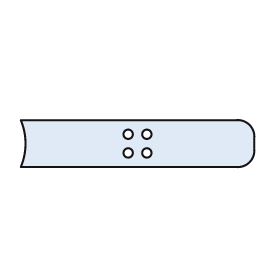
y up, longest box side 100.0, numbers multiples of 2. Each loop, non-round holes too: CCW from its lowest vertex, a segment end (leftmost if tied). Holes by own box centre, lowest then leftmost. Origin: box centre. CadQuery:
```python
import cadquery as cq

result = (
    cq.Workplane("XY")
    .moveTo(-50.0, -10.0)
    .lineTo(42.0, -10.0)
    .threePointArc((48.0, -8.0), (50.0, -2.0))
    .lineTo(50.0, 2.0)
    .threePointArc((48.0, 8.0), (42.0, 10.0))
    .lineTo(-50.0, 10.0)
    .threePointArc((-48.0, 0.0), (-50.0, -10.0))
    .close()
    .moveTo(-4.0, -4.0)
    .circle(2.0)
    .moveTo(4.0, -4.0)
    .circle(2.0)
    .moveTo(-4.0, 4.0)
    .circle(2.0)
    .moveTo(4.0, 4.0)
    .circle(2.0)
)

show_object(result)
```